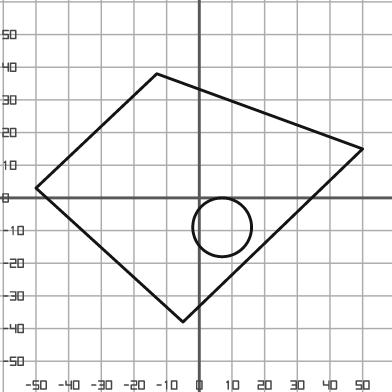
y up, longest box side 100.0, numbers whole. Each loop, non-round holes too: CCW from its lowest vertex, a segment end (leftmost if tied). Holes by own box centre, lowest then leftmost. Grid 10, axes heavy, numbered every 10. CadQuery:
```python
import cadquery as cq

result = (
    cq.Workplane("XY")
    .moveTo(-5.0, -38.0)
    .lineTo(50.0, 15.0)
    .lineTo(-13.0, 38.0)
    .lineTo(-50.0, 3.0)
    .close()
    .moveTo(7.0, -9.0)
    .circle(9.0)
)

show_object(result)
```